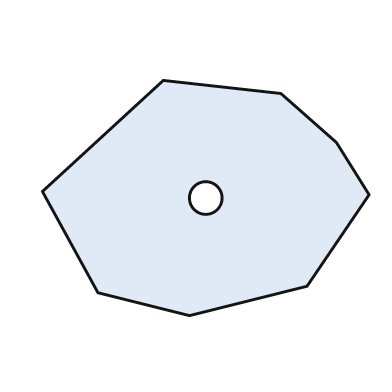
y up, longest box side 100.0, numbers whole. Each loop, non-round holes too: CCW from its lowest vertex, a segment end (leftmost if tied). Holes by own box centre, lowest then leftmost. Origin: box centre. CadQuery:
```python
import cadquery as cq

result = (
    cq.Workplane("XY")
    .moveTo(-5.0, -36.0)
    .lineTo(31.0, -27.0)
    .lineTo(50.0, 1.0)
    .lineTo(40.0, 17.0)
    .lineTo(23.0, 32.0)
    .lineTo(-13.0, 36.0)
    .lineTo(-50.0, 2.0)
    .lineTo(-33.0, -29.0)
    .close()
    .moveTo(0.0, 0.0)
    .circle(5.0)
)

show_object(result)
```